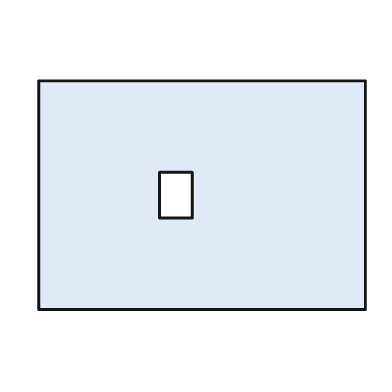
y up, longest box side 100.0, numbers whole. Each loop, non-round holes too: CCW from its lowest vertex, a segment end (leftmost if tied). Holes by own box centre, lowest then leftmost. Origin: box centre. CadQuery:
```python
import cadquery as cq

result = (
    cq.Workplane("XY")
    .moveTo(-50.0, -35.0)
    .lineTo(50.0, -35.0)
    .lineTo(50.0, 35.0)
    .lineTo(-50.0, 35.0)
    .close()
    .moveTo(-13.0, -7.0)
    .lineTo(-3.0, -7.0)
    .lineTo(-3.0, 7.0)
    .lineTo(-13.0, 7.0)
    .close()
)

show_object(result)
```